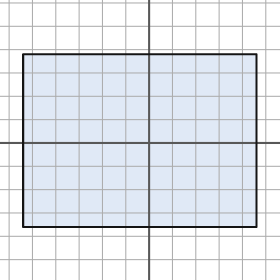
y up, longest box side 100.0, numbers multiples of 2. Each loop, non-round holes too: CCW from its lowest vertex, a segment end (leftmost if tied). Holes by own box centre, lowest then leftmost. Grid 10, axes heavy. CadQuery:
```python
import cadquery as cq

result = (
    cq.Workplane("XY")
    .moveTo(-54.0, -36.0)
    .lineTo(46.0, -36.0)
    .lineTo(46.0, 38.0)
    .lineTo(-54.0, 38.0)
    .close()
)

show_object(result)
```